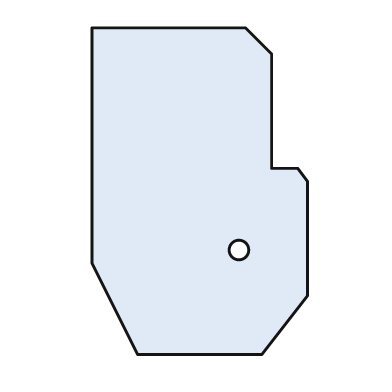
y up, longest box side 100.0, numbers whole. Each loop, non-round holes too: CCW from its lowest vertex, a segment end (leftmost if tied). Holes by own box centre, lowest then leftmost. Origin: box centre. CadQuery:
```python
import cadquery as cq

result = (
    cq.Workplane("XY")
    .moveTo(-19.0, -50.0)
    .lineTo(19.0, -50.0)
    .lineTo(33.0, -32.0)
    .lineTo(33.0, 3.0)
    .lineTo(30.0, 7.0)
    .lineTo(22.0, 7.0)
    .lineTo(22.0, 42.0)
    .lineTo(14.0, 50.0)
    .lineTo(-33.0, 50.0)
    .lineTo(-33.0, -22.0)
    .close()
    .moveTo(12.0, -18.0)
    .circle(3.0)
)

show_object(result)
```